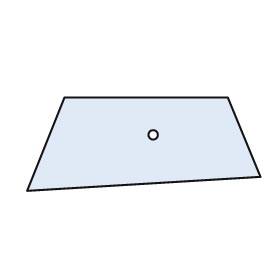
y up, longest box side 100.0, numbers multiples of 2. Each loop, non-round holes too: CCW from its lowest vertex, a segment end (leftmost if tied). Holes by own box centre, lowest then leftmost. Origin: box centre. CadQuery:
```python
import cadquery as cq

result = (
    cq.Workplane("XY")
    .moveTo(-50.0, -20.0)
    .lineTo(50.0, -14.0)
    .lineTo(36.0, 20.0)
    .lineTo(-34.0, 20.0)
    .close()
    .moveTo(4.0, 4.0)
    .circle(2.0)
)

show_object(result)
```